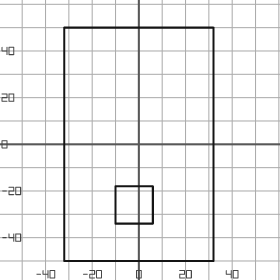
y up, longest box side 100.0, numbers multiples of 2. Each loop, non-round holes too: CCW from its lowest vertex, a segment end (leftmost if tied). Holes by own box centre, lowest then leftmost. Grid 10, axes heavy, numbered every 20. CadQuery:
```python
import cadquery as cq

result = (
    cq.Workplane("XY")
    .moveTo(-32.0, -50.0)
    .lineTo(32.0, -50.0)
    .lineTo(32.0, 50.0)
    .lineTo(-32.0, 50.0)
    .close()
    .moveTo(-10.0, -34.0)
    .lineTo(6.0, -34.0)
    .lineTo(6.0, -18.0)
    .lineTo(-10.0, -18.0)
    .close()
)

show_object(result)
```